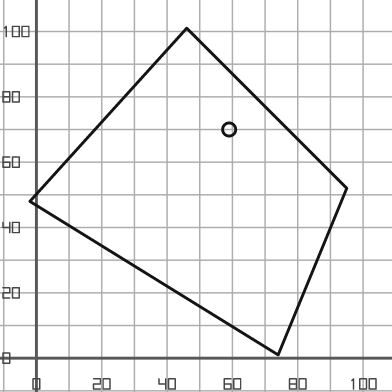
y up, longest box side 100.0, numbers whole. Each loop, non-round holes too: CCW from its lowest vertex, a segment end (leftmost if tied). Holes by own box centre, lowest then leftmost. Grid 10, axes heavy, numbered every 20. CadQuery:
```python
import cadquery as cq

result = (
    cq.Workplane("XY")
    .moveTo(74.0, 1.0)
    .lineTo(95.0, 52.0)
    .lineTo(46.0, 101.0)
    .lineTo(-2.0, 48.0)
    .close()
    .moveTo(59.0, 70.0)
    .circle(2.0)
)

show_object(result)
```